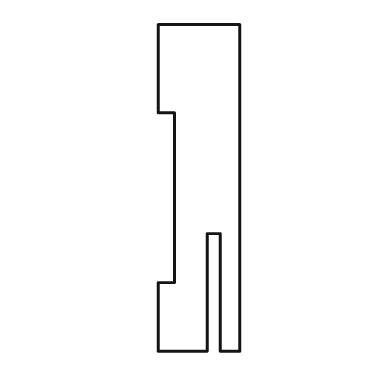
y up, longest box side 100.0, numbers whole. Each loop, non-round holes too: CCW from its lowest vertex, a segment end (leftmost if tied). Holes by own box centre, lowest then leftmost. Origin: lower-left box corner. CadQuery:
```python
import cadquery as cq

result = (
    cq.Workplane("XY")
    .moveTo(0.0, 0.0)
    .lineTo(15.0, 0.0)
    .lineTo(15.0, 36.0)
    .lineTo(19.0, 36.0)
    .lineTo(19.0, 0.0)
    .lineTo(25.0, 0.0)
    .lineTo(25.0, 100.0)
    .lineTo(0.0, 100.0)
    .lineTo(0.0, 73.0)
    .lineTo(5.0, 73.0)
    .lineTo(5.0, 21.0)
    .lineTo(0.0, 21.0)
    .close()
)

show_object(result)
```